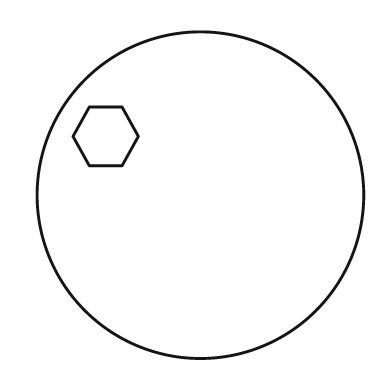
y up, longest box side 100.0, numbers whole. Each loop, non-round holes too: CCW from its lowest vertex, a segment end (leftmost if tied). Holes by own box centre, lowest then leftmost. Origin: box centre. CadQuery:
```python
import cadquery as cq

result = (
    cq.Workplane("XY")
    .moveTo(0.0, 0.0)
    .circle(50.0)
    .moveTo(-34.0, 9.0)
    .lineTo(-24.0, 9.0)
    .lineTo(-19.0, 18.0)
    .lineTo(-24.0, 27.0)
    .lineTo(-34.0, 27.0)
    .lineTo(-39.0, 18.0)
    .close()
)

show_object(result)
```